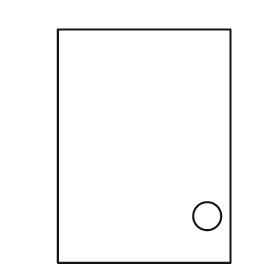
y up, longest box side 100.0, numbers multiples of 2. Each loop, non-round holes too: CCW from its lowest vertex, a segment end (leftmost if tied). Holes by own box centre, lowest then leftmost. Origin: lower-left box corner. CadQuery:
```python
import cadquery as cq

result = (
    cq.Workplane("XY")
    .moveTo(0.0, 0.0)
    .lineTo(74.0, 0.0)
    .lineTo(74.0, 100.0)
    .lineTo(0.0, 100.0)
    .close()
    .moveTo(64.0, 20.0)
    .circle(6.0)
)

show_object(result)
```